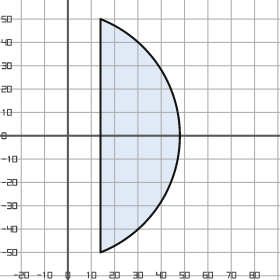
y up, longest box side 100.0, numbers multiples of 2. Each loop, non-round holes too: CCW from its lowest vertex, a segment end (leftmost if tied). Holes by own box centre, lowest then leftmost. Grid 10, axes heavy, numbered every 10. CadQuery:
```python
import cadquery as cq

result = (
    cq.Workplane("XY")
    .moveTo(14.0, -50.0)
    .threePointArc((48.0, 0.0), (14.0, 50.0))
    .close()
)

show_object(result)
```